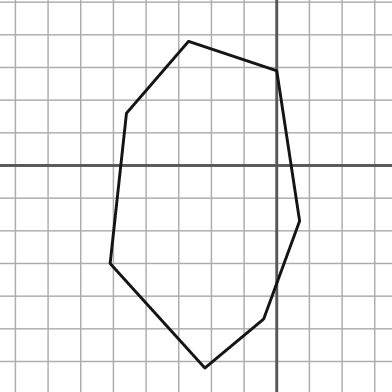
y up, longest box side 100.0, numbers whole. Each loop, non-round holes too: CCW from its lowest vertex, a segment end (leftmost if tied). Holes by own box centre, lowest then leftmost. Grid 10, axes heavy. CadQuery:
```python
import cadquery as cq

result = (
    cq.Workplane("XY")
    .moveTo(-22.0, -62.0)
    .lineTo(-4.0, -47.0)
    .lineTo(7.0, -17.0)
    .lineTo(0.0, 29.0)
    .lineTo(-27.0, 38.0)
    .lineTo(-46.0, 16.0)
    .lineTo(-51.0, -30.0)
    .close()
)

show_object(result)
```